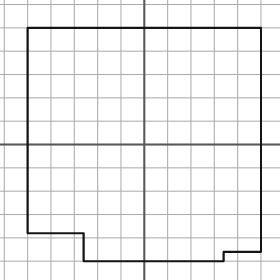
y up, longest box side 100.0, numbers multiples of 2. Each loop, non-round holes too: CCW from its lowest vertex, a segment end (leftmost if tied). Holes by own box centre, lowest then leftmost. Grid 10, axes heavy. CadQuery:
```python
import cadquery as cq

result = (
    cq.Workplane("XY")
    .moveTo(-26.0, -50.0)
    .lineTo(34.0, -50.0)
    .lineTo(34.0, -46.0)
    .lineTo(50.0, -46.0)
    .lineTo(50.0, 50.0)
    .lineTo(-50.0, 50.0)
    .lineTo(-50.0, -38.0)
    .lineTo(-26.0, -38.0)
    .close()
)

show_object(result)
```